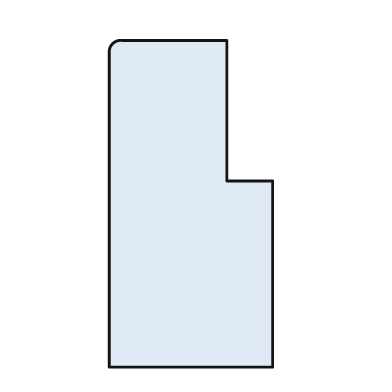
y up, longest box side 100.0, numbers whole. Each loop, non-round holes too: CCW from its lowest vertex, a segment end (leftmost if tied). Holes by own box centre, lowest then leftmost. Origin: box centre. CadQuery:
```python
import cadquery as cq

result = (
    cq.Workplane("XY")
    .moveTo(-25.0, -50.0)
    .lineTo(25.0, -50.0)
    .lineTo(25.0, 7.0)
    .lineTo(11.0, 7.0)
    .lineTo(11.0, 50.0)
    .lineTo(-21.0, 50.0)
    .threePointArc((-24.0, 49.0), (-25.0, 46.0))
    .close()
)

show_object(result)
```